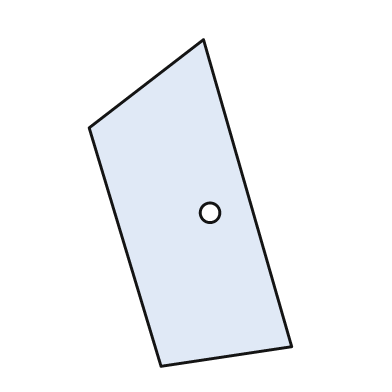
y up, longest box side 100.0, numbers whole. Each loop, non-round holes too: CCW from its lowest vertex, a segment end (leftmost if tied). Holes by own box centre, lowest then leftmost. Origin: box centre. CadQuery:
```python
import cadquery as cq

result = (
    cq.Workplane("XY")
    .moveTo(-9.0, -50.0)
    .lineTo(31.0, -44.0)
    .lineTo(4.0, 50.0)
    .lineTo(-31.0, 23.0)
    .close()
    .moveTo(6.0, -3.0)
    .circle(3.0)
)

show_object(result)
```